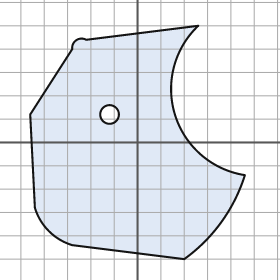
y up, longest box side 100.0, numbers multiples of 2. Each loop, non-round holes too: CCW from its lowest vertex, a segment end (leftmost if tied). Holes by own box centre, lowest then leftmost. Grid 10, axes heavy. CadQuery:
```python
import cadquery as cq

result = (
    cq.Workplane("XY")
    .moveTo(20.0, -50.0)
    .threePointArc((36.0, -34.0), (46.0, -14.0))
    .threePointArc((16.0, 12.0), (26.0, 50.0))
    .lineTo(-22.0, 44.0)
    .threePointArc((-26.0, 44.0), (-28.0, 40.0))
    .lineTo(-46.0, 12.0)
    .lineTo(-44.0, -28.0)
    .threePointArc((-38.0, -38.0), (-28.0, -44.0))
    .close()
    .moveTo(-12.0, 12.0)
    .circle(4.0)
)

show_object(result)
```